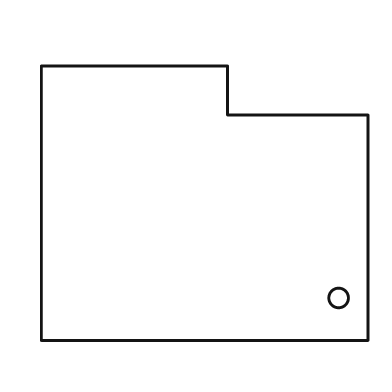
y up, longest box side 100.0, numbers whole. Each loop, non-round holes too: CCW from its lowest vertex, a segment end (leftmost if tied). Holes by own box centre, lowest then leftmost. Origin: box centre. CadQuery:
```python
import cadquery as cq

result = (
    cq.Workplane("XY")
    .moveTo(-50.0, -42.0)
    .lineTo(50.0, -42.0)
    .lineTo(50.0, 27.0)
    .lineTo(7.0, 27.0)
    .lineTo(7.0, 42.0)
    .lineTo(-50.0, 42.0)
    .close()
    .moveTo(41.0, -29.0)
    .circle(3.0)
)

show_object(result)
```